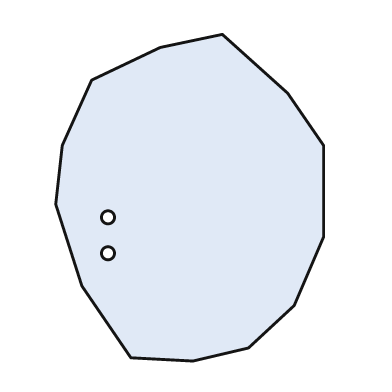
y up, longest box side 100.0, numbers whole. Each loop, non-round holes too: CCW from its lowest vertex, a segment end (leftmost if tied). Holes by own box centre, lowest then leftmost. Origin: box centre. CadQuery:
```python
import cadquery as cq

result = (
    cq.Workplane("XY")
    .moveTo(1.0, -50.0)
    .lineTo(18.0, -46.0)
    .lineTo(32.0, -33.0)
    .lineTo(41.0, -12.0)
    .lineTo(41.0, 16.0)
    .lineTo(30.0, 32.0)
    .lineTo(10.0, 50.0)
    .lineTo(-9.0, 46.0)
    .lineTo(-30.0, 36.0)
    .lineTo(-39.0, 16.0)
    .lineTo(-41.0, -2.0)
    .lineTo(-33.0, -27.0)
    .lineTo(-18.0, -49.0)
    .close()
    .moveTo(-25.0, -17.0)
    .circle(2.0)
    .moveTo(-25.0, -6.0)
    .circle(2.0)
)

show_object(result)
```